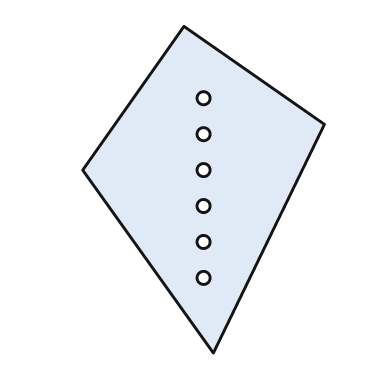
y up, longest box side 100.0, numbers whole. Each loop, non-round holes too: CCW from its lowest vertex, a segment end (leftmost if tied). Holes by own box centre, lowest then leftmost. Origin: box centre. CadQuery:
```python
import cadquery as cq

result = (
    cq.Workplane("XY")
    .moveTo(3.0, -50.0)
    .lineTo(37.0, 20.0)
    .lineTo(-6.0, 50.0)
    .lineTo(-37.0, 6.0)
    .close()
    .moveTo(0.0, -27.0)
    .circle(2.0)
    .moveTo(0.0, -16.0)
    .circle(2.0)
    .moveTo(0.0, -5.0)
    .circle(2.0)
    .moveTo(0.0, 6.0)
    .circle(2.0)
    .moveTo(0.0, 17.0)
    .circle(2.0)
    .moveTo(0.0, 28.0)
    .circle(2.0)
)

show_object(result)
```